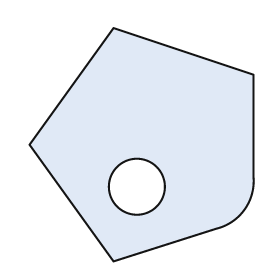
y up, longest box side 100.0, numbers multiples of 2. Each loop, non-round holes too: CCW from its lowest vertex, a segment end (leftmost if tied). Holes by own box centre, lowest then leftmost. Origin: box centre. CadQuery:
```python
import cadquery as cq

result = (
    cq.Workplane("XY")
    .moveTo(-12.0, -50.0)
    .lineTo(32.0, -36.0)
    .threePointArc((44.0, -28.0), (48.0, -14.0))
    .lineTo(48.0, 30.0)
    .lineTo(-12.0, 50.0)
    .lineTo(-48.0, 0.0)
    .close()
    .moveTo(-2.0, -18.0)
    .circle(12.0)
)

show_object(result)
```